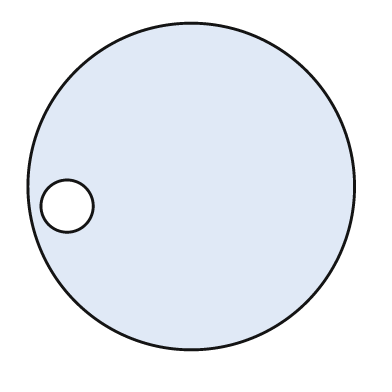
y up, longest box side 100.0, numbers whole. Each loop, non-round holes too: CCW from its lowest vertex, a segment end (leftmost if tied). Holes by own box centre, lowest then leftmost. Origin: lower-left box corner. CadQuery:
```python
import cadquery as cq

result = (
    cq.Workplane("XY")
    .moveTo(50.0, 50.0)
    .circle(50.0)
    .moveTo(12.0, 44.0)
    .circle(8.0)
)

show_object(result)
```